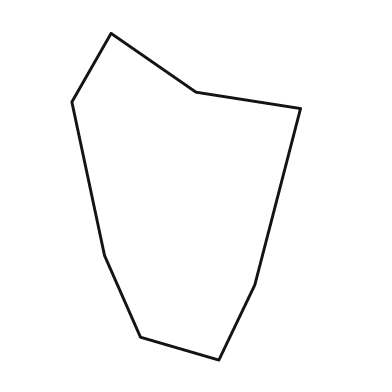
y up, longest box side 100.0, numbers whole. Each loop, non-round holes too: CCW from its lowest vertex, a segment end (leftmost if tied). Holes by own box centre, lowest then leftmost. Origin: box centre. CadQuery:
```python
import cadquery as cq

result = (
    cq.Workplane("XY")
    .moveTo(10.0, -50.0)
    .lineTo(21.0, -27.0)
    .lineTo(35.0, 27.0)
    .lineTo(3.0, 32.0)
    .lineTo(-23.0, 50.0)
    .lineTo(-35.0, 29.0)
    .lineTo(-25.0, -18.0)
    .lineTo(-14.0, -43.0)
    .close()
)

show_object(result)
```